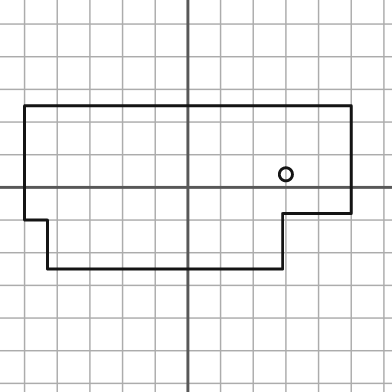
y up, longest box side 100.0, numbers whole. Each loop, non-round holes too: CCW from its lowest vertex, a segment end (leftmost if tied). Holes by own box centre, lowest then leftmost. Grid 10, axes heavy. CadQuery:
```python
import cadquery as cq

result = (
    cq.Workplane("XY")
    .moveTo(-43.0, -25.0)
    .lineTo(29.0, -25.0)
    .lineTo(29.0, -8.0)
    .lineTo(50.0, -8.0)
    .lineTo(50.0, 25.0)
    .lineTo(-50.0, 25.0)
    .lineTo(-50.0, -10.0)
    .lineTo(-43.0, -10.0)
    .close()
    .moveTo(30.0, 4.0)
    .circle(2.0)
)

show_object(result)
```